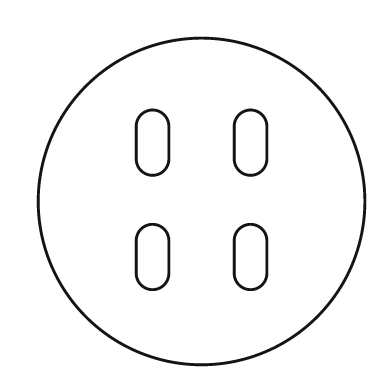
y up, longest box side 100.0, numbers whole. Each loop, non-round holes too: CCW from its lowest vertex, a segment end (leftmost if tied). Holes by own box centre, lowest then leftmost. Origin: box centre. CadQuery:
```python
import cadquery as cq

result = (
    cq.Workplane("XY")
    .moveTo(0.0, 0.0)
    .circle(50.0)
    .moveTo(-20.0, -22.0)
    .threePointArc((-15.0, -27.0), (-10.0, -22.0))
    .lineTo(-10.0, -12.0)
    .threePointArc((-15.0, -7.0), (-20.0, -12.0))
    .close()
    .moveTo(10.0, -22.0)
    .threePointArc((15.0, -27.0), (20.0, -22.0))
    .lineTo(20.0, -12.0)
    .threePointArc((15.0, -7.0), (10.0, -12.0))
    .close()
    .moveTo(-20.0, 13.0)
    .threePointArc((-15.0, 8.0), (-10.0, 13.0))
    .lineTo(-10.0, 23.0)
    .threePointArc((-15.0, 28.0), (-20.0, 23.0))
    .close()
    .moveTo(10.0, 13.0)
    .threePointArc((15.0, 8.0), (20.0, 13.0))
    .lineTo(20.0, 23.0)
    .threePointArc((15.0, 28.0), (10.0, 23.0))
    .close()
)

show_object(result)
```